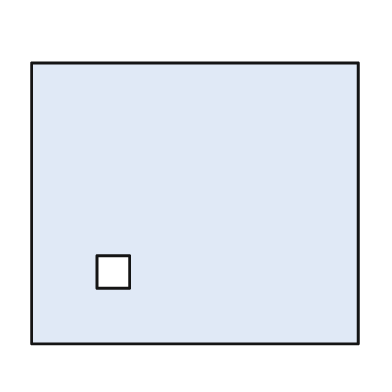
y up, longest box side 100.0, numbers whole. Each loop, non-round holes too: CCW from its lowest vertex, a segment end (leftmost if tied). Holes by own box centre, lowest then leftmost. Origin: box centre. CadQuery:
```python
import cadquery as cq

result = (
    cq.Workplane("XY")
    .moveTo(-50.0, -43.0)
    .lineTo(50.0, -43.0)
    .lineTo(50.0, 43.0)
    .lineTo(-50.0, 43.0)
    .close()
    .moveTo(-30.0, -26.0)
    .lineTo(-20.0, -26.0)
    .lineTo(-20.0, -16.0)
    .lineTo(-30.0, -16.0)
    .close()
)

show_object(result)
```